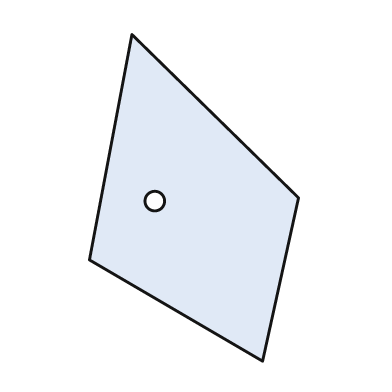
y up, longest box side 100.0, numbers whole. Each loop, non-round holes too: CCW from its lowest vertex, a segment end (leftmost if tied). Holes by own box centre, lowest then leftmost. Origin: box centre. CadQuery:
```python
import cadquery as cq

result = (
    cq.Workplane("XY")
    .moveTo(21.0, -50.0)
    .lineTo(32.0, 0.0)
    .lineTo(-19.0, 50.0)
    .lineTo(-32.0, -19.0)
    .close()
    .moveTo(-12.0, -1.0)
    .circle(3.0)
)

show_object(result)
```